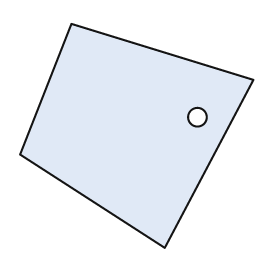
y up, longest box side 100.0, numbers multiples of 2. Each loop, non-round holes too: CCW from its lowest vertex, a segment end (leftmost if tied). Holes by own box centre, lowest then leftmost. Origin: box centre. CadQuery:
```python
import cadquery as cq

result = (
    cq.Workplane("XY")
    .moveTo(12.0, -48.0)
    .lineTo(50.0, 24.0)
    .lineTo(-28.0, 48.0)
    .lineTo(-50.0, -8.0)
    .close()
    .moveTo(26.0, 8.0)
    .circle(4.0)
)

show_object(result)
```